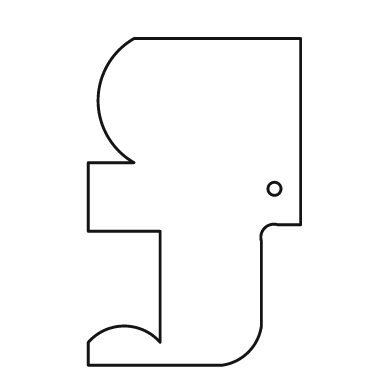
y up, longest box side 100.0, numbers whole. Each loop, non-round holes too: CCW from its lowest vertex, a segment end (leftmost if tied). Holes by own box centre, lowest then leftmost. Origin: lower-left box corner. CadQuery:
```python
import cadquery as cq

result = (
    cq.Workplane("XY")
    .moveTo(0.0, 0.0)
    .lineTo(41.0, 0.0)
    .threePointArc((49.0, 4.0), (53.0, 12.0))
    .lineTo(53.0, 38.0)
    .threePointArc((54.0, 42.0), (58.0, 43.0))
    .lineTo(65.0, 43.0)
    .lineTo(65.0, 100.0)
    .lineTo(14.0, 100.0)
    .threePointArc((3.0, 81.0), (14.0, 62.0))
    .lineTo(0.0, 62.0)
    .lineTo(0.0, 41.0)
    .lineTo(22.0, 41.0)
    .lineTo(22.0, 7.0)
    .threePointArc((11.0, 12.0), (0.0, 7.0))
    .close()
    .moveTo(57.0, 54.0)
    .circle(2.0)
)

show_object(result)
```